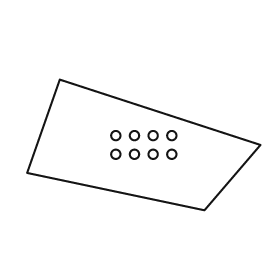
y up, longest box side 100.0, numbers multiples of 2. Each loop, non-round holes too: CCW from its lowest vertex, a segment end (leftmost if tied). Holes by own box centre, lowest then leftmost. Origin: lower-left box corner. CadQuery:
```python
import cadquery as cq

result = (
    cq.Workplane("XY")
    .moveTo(76.0, 0.0)
    .lineTo(100.0, 28.0)
    .lineTo(14.0, 56.0)
    .lineTo(0.0, 16.0)
    .close()
    .moveTo(38.0, 24.0)
    .circle(2.0)
    .moveTo(46.0, 24.0)
    .circle(2.0)
    .moveTo(54.0, 24.0)
    .circle(2.0)
    .moveTo(62.0, 24.0)
    .circle(2.0)
    .moveTo(38.0, 32.0)
    .circle(2.0)
    .moveTo(46.0, 32.0)
    .circle(2.0)
    .moveTo(54.0, 32.0)
    .circle(2.0)
    .moveTo(62.0, 32.0)
    .circle(2.0)
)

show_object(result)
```